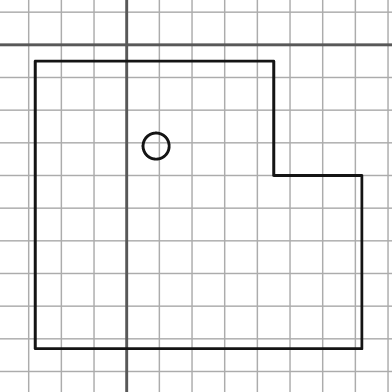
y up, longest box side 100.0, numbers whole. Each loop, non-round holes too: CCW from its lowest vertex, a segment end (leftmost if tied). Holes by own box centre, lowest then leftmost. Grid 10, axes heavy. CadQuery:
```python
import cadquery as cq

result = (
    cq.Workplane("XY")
    .moveTo(-28.0, -93.0)
    .lineTo(72.0, -93.0)
    .lineTo(72.0, -40.0)
    .lineTo(45.0, -40.0)
    .lineTo(45.0, -5.0)
    .lineTo(-28.0, -5.0)
    .close()
    .moveTo(9.0, -31.0)
    .circle(4.0)
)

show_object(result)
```